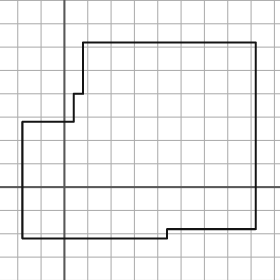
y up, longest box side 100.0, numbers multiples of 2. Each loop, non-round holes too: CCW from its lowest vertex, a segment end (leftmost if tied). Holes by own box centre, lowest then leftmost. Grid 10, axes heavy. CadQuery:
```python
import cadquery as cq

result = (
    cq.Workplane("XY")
    .moveTo(-18.0, -22.0)
    .lineTo(44.0, -22.0)
    .lineTo(44.0, -18.0)
    .lineTo(82.0, -18.0)
    .lineTo(82.0, 62.0)
    .lineTo(8.0, 62.0)
    .lineTo(8.0, 40.0)
    .lineTo(4.0, 40.0)
    .lineTo(4.0, 28.0)
    .lineTo(-18.0, 28.0)
    .close()
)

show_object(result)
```